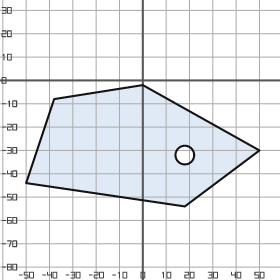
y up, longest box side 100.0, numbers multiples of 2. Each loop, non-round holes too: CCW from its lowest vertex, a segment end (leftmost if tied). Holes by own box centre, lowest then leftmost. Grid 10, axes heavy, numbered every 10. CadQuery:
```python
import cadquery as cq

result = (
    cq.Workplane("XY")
    .moveTo(18.0, -54.0)
    .lineTo(50.0, -30.0)
    .lineTo(0.0, -2.0)
    .lineTo(-38.0, -8.0)
    .lineTo(-50.0, -44.0)
    .close()
    .moveTo(18.0, -32.0)
    .circle(4.0)
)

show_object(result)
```